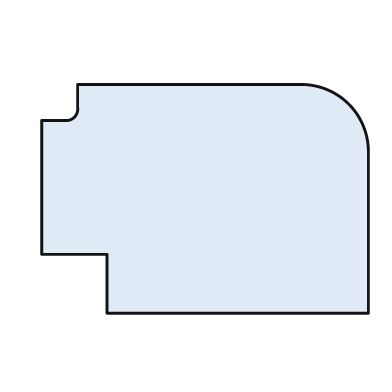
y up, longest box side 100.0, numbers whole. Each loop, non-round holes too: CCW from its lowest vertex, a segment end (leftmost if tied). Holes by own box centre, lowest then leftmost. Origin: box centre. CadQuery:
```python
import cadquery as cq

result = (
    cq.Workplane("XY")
    .moveTo(-30.0, -35.0)
    .lineTo(50.0, -35.0)
    .lineTo(50.0, 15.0)
    .threePointArc((44.0, 29.0), (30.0, 35.0))
    .lineTo(-39.0, 35.0)
    .lineTo(-39.0, 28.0)
    .threePointArc((-40.0, 25.0), (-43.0, 24.0))
    .lineTo(-50.0, 24.0)
    .lineTo(-50.0, -17.0)
    .lineTo(-30.0, -17.0)
    .close()
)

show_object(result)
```